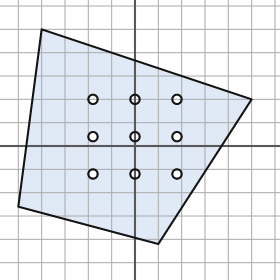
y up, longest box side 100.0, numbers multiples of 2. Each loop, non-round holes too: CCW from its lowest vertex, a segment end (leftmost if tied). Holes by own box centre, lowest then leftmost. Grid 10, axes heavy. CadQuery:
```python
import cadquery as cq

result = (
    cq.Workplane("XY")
    .moveTo(10.0, -42.0)
    .lineTo(50.0, 20.0)
    .lineTo(-40.0, 50.0)
    .lineTo(-50.0, -26.0)
    .close()
    .moveTo(-18.0, -12.0)
    .circle(2.0)
    .moveTo(0.0, -12.0)
    .circle(2.0)
    .moveTo(18.0, -12.0)
    .circle(2.0)
    .moveTo(-18.0, 4.0)
    .circle(2.0)
    .moveTo(0.0, 4.0)
    .circle(2.0)
    .moveTo(18.0, 4.0)
    .circle(2.0)
    .moveTo(-18.0, 20.0)
    .circle(2.0)
    .moveTo(0.0, 20.0)
    .circle(2.0)
    .moveTo(18.0, 20.0)
    .circle(2.0)
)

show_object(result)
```